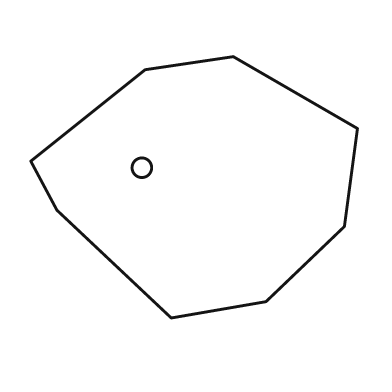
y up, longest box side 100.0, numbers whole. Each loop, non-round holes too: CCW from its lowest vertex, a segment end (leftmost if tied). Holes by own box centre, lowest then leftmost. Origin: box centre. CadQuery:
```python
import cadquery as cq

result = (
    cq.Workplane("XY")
    .moveTo(-7.0, -40.0)
    .lineTo(22.0, -35.0)
    .lineTo(46.0, -12.0)
    .lineTo(50.0, 18.0)
    .lineTo(12.0, 40.0)
    .lineTo(-15.0, 36.0)
    .lineTo(-50.0, 8.0)
    .lineTo(-42.0, -7.0)
    .close()
    .moveTo(-16.0, 6.0)
    .circle(3.0)
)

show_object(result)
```